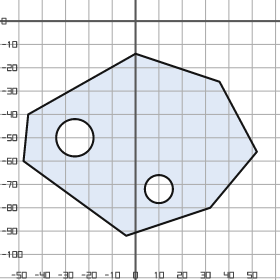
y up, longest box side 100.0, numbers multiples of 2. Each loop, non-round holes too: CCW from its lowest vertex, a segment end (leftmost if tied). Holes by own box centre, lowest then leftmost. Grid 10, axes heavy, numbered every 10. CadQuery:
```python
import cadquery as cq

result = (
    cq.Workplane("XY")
    .moveTo(-4.0, -92.0)
    .lineTo(32.0, -80.0)
    .lineTo(52.0, -56.0)
    .lineTo(36.0, -26.0)
    .lineTo(0.0, -14.0)
    .lineTo(-46.0, -40.0)
    .lineTo(-48.0, -60.0)
    .close()
    .moveTo(10.0, -72.0)
    .circle(6.0)
    .moveTo(-26.0, -50.0)
    .circle(8.0)
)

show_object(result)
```